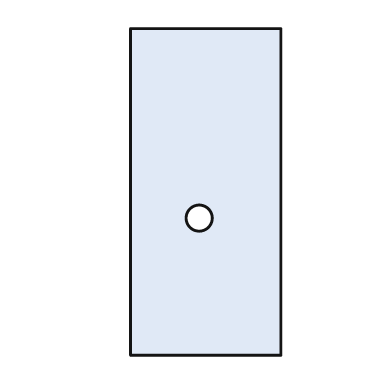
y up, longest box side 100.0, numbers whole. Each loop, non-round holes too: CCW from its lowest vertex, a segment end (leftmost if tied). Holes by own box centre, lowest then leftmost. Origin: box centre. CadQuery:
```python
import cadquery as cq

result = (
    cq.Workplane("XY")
    .moveTo(-23.0, -50.0)
    .lineTo(23.0, -50.0)
    .lineTo(23.0, 50.0)
    .lineTo(-23.0, 50.0)
    .close()
    .moveTo(-2.0, -8.0)
    .circle(4.0)
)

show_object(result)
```